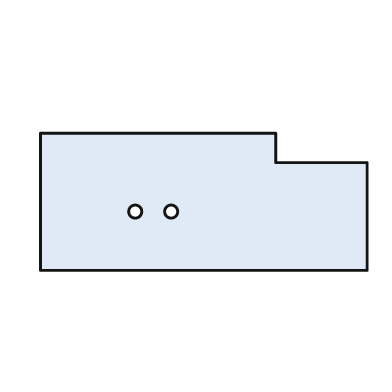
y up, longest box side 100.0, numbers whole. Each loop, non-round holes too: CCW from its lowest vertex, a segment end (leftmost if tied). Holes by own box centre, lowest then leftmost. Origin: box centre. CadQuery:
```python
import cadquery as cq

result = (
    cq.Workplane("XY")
    .moveTo(-50.0, -21.0)
    .lineTo(50.0, -21.0)
    .lineTo(50.0, 12.0)
    .lineTo(22.0, 12.0)
    .lineTo(22.0, 21.0)
    .lineTo(-50.0, 21.0)
    .close()
    .moveTo(-21.0, -3.0)
    .circle(2.0)
    .moveTo(-10.0, -3.0)
    .circle(2.0)
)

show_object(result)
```